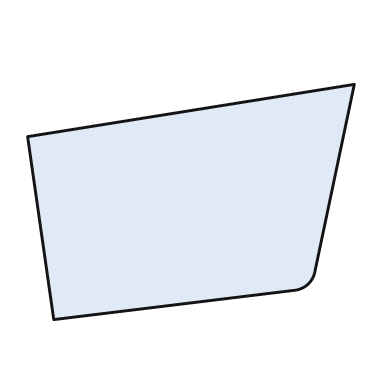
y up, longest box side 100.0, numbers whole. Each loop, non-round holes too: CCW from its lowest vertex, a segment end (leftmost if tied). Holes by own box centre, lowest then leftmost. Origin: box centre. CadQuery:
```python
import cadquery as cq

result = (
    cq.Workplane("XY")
    .moveTo(-42.0, -36.0)
    .lineTo(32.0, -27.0)
    .threePointArc((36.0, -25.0), (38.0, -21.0))
    .lineTo(50.0, 36.0)
    .lineTo(-50.0, 20.0)
    .close()
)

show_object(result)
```